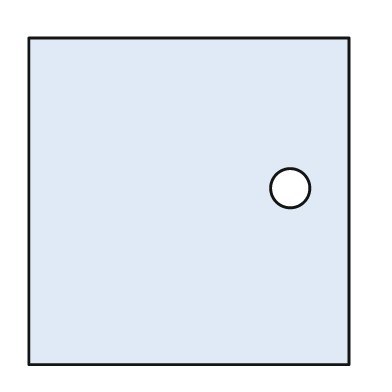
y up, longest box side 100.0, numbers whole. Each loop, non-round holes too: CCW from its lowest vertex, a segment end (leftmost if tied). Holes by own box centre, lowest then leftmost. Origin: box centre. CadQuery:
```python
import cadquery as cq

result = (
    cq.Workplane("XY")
    .moveTo(-49.0, -50.0)
    .lineTo(49.0, -50.0)
    .lineTo(49.0, 50.0)
    .lineTo(-49.0, 50.0)
    .close()
    .moveTo(31.0, 4.0)
    .circle(6.0)
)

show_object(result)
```